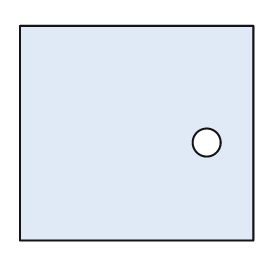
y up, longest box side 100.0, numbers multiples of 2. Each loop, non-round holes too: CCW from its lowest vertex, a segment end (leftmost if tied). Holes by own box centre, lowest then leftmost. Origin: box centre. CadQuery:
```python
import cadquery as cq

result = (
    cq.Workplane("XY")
    .moveTo(-50.0, -46.0)
    .lineTo(50.0, -46.0)
    .lineTo(50.0, 46.0)
    .lineTo(-50.0, 46.0)
    .close()
    .moveTo(30.0, -4.0)
    .circle(6.0)
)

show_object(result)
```